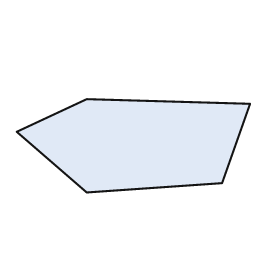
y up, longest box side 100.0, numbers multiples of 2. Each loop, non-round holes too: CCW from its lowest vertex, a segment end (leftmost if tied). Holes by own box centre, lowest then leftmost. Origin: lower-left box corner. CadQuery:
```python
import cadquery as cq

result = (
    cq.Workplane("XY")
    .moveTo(30.0, 0.0)
    .lineTo(88.0, 4.0)
    .lineTo(100.0, 38.0)
    .lineTo(30.0, 40.0)
    .lineTo(0.0, 26.0)
    .close()
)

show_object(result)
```